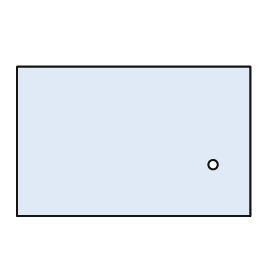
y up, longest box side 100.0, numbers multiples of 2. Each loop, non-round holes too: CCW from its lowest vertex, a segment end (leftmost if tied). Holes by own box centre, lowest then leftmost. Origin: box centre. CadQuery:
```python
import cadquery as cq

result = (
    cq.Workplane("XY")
    .moveTo(-50.0, -32.0)
    .lineTo(50.0, -32.0)
    .lineTo(50.0, 32.0)
    .lineTo(-50.0, 32.0)
    .close()
    .moveTo(34.0, -10.0)
    .circle(2.0)
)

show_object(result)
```